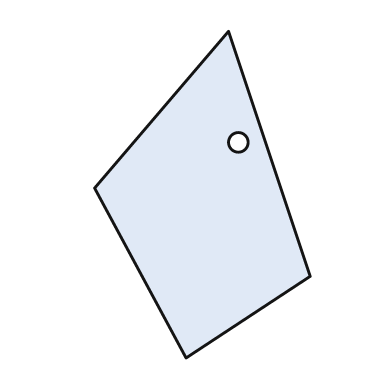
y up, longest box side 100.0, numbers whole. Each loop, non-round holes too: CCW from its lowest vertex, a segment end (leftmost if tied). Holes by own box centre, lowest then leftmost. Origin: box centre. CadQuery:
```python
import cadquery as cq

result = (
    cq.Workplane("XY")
    .moveTo(-5.0, -50.0)
    .lineTo(33.0, -25.0)
    .lineTo(8.0, 50.0)
    .lineTo(-33.0, 2.0)
    .close()
    .moveTo(11.0, 16.0)
    .circle(3.0)
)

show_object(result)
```